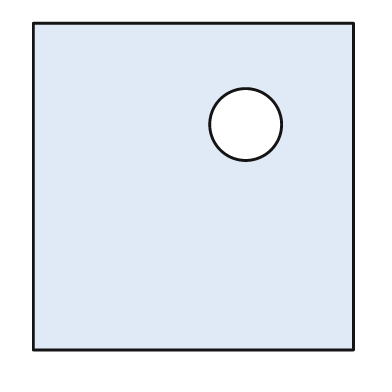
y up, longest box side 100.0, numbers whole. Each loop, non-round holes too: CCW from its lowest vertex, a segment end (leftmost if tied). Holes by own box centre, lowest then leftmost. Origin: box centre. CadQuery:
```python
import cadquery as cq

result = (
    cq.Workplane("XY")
    .moveTo(-49.0, -50.0)
    .lineTo(49.0, -50.0)
    .lineTo(49.0, 50.0)
    .lineTo(-49.0, 50.0)
    .close()
    .moveTo(16.0, 19.0)
    .circle(11.0)
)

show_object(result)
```